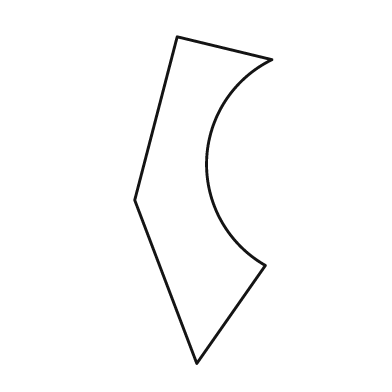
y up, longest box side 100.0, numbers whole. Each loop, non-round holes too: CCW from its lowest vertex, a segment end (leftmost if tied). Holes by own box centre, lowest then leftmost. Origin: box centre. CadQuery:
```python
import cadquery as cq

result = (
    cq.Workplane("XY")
    .moveTo(-2.0, -50.0)
    .lineTo(19.0, -20.0)
    .threePointArc((1.0, 12.0), (21.0, 43.0))
    .lineTo(-8.0, 50.0)
    .lineTo(-21.0, 0.0)
    .close()
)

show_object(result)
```